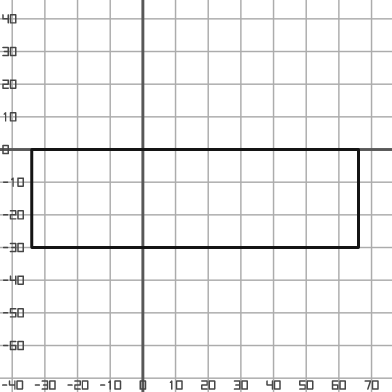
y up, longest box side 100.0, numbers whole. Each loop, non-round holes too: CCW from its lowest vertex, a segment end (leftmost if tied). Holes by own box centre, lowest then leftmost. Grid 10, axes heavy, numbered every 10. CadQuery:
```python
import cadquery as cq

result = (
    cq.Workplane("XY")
    .moveTo(-34.0, -30.0)
    .lineTo(66.0, -30.0)
    .lineTo(66.0, 0.0)
    .lineTo(-34.0, 0.0)
    .close()
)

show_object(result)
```